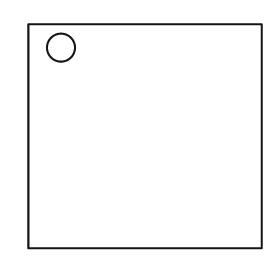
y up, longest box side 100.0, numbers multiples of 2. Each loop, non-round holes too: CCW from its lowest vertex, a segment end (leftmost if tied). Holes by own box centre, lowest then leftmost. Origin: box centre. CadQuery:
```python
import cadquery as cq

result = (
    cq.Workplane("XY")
    .moveTo(-50.0, -48.0)
    .lineTo(50.0, -48.0)
    .lineTo(50.0, 48.0)
    .lineTo(-50.0, 48.0)
    .close()
    .moveTo(-36.0, 38.0)
    .circle(6.0)
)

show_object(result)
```